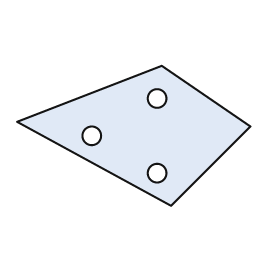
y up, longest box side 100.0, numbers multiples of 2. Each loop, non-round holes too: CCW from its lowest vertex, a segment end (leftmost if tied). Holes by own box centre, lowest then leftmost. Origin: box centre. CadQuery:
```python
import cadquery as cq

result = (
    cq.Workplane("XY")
    .moveTo(16.0, -30.0)
    .lineTo(50.0, 4.0)
    .lineTo(12.0, 30.0)
    .lineTo(-50.0, 6.0)
    .close()
    .moveTo(10.0, -16.0)
    .circle(4.0)
    .moveTo(-18.0, 0.0)
    .circle(4.0)
    .moveTo(10.0, 16.0)
    .circle(4.0)
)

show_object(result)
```